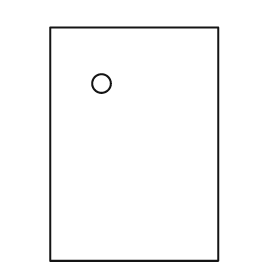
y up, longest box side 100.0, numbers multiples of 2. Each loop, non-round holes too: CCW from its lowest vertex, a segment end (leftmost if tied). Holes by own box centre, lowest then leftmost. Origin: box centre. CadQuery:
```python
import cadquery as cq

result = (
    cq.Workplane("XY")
    .moveTo(-36.0, -50.0)
    .lineTo(36.0, -50.0)
    .lineTo(36.0, 50.0)
    .lineTo(-36.0, 50.0)
    .close()
    .moveTo(-14.0, 26.0)
    .circle(4.0)
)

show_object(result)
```